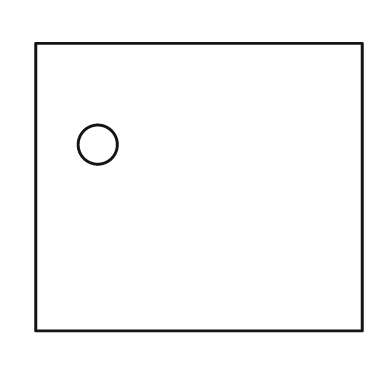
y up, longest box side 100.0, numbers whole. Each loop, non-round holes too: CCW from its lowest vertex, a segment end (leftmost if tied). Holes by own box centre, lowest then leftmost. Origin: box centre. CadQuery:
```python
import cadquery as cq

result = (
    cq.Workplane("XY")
    .moveTo(-50.0, -44.0)
    .lineTo(50.0, -44.0)
    .lineTo(50.0, 44.0)
    .lineTo(-50.0, 44.0)
    .close()
    .moveTo(-31.0, 13.0)
    .circle(6.0)
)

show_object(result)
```